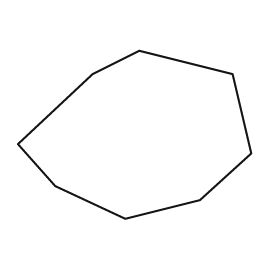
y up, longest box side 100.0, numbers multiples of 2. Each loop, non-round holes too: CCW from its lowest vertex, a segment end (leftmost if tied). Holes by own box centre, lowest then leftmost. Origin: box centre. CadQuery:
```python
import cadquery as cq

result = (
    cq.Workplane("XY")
    .moveTo(-4.0, -36.0)
    .lineTo(28.0, -28.0)
    .lineTo(50.0, -8.0)
    .lineTo(42.0, 26.0)
    .lineTo(2.0, 36.0)
    .lineTo(-18.0, 26.0)
    .lineTo(-50.0, -4.0)
    .lineTo(-34.0, -22.0)
    .close()
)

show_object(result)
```